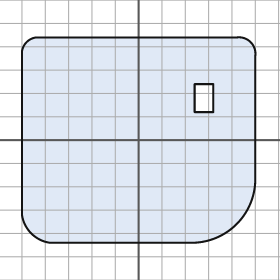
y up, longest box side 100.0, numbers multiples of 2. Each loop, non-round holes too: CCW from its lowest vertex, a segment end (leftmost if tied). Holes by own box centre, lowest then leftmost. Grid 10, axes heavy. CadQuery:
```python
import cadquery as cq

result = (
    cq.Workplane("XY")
    .moveTo(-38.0, -44.0)
    .lineTo(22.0, -44.0)
    .threePointArc((42.0, -36.0), (50.0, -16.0))
    .lineTo(50.0, 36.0)
    .threePointArc((48.0, 42.0), (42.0, 44.0))
    .lineTo(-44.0, 44.0)
    .threePointArc((-48.0, 42.0), (-50.0, 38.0))
    .lineTo(-50.0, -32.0)
    .threePointArc((-46.0, -40.0), (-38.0, -44.0))
    .close()
    .moveTo(24.0, 12.0)
    .lineTo(32.0, 12.0)
    .lineTo(32.0, 24.0)
    .lineTo(24.0, 24.0)
    .close()
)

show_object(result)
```